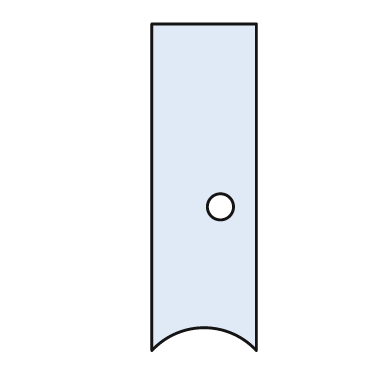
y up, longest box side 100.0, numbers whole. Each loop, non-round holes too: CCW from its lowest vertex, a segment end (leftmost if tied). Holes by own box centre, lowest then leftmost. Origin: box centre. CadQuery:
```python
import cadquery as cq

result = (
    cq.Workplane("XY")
    .moveTo(-16.0, -50.0)
    .threePointArc((0.0, -43.0), (16.0, -50.0))
    .lineTo(16.0, 50.0)
    .lineTo(-16.0, 50.0)
    .close()
    .moveTo(5.0, -6.0)
    .circle(4.0)
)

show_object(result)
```